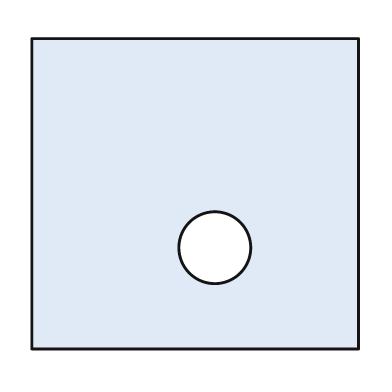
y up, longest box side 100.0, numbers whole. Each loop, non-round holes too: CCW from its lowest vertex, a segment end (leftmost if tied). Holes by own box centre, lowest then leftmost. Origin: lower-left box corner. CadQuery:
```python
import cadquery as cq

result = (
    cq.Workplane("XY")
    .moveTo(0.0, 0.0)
    .lineTo(100.0, 0.0)
    .lineTo(100.0, 95.0)
    .lineTo(0.0, 95.0)
    .close()
    .moveTo(56.0, 31.0)
    .circle(11.0)
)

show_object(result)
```